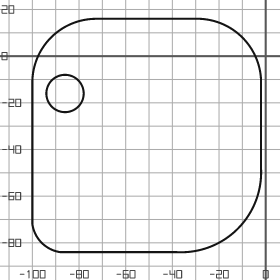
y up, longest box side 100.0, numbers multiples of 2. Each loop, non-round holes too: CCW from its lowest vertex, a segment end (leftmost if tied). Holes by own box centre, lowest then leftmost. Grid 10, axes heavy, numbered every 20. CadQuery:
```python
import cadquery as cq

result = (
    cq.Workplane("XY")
    .moveTo(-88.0, -84.0)
    .lineTo(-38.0, -84.0)
    .threePointArc((-12.0, -74.0), (-2.0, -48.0))
    .lineTo(-2.0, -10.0)
    .threePointArc((-10.0, 8.0), (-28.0, 16.0))
    .lineTo(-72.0, 16.0)
    .threePointArc((-92.0, 8.0), (-100.0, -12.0))
    .lineTo(-100.0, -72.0)
    .threePointArc((-96.0, -80.0), (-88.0, -84.0))
    .close()
    .moveTo(-86.0, -16.0)
    .circle(8.0)
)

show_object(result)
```